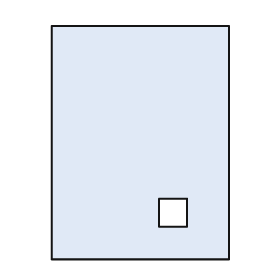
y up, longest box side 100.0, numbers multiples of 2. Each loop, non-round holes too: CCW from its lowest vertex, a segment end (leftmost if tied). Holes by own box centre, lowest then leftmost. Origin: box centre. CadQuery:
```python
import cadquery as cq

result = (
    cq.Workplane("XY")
    .moveTo(-38.0, -50.0)
    .lineTo(38.0, -50.0)
    .lineTo(38.0, 50.0)
    .lineTo(-38.0, 50.0)
    .close()
    .moveTo(8.0, -36.0)
    .lineTo(20.0, -36.0)
    .lineTo(20.0, -24.0)
    .lineTo(8.0, -24.0)
    .close()
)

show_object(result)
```